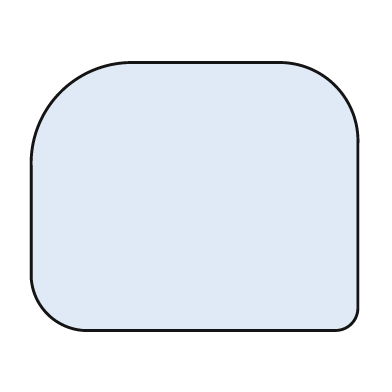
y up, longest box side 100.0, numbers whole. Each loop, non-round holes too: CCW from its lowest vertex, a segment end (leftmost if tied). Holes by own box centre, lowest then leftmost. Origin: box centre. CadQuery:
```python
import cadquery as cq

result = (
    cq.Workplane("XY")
    .moveTo(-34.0, -41.0)
    .lineTo(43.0, -41.0)
    .threePointArc((48.0, -39.0), (50.0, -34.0))
    .lineTo(50.0, 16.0)
    .threePointArc((43.0, 34.0), (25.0, 41.0))
    .lineTo(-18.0, 41.0)
    .threePointArc((-41.0, 32.0), (-50.0, 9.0))
    .lineTo(-50.0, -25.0)
    .threePointArc((-45.0, -36.0), (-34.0, -41.0))
    .close()
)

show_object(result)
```